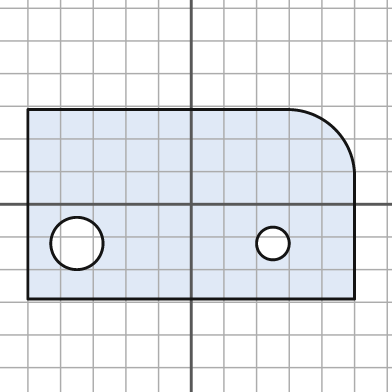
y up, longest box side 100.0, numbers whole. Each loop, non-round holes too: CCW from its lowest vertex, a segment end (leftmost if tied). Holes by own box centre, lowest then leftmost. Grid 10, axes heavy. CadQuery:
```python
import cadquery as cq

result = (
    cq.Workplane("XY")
    .moveTo(-50.0, -29.0)
    .lineTo(50.0, -29.0)
    .lineTo(50.0, 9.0)
    .threePointArc((44.0, 23.0), (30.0, 29.0))
    .lineTo(-50.0, 29.0)
    .close()
    .moveTo(-35.0, -12.0)
    .circle(8.0)
    .moveTo(25.0, -12.0)
    .circle(5.0)
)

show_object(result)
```